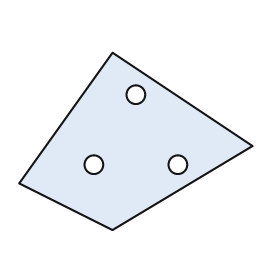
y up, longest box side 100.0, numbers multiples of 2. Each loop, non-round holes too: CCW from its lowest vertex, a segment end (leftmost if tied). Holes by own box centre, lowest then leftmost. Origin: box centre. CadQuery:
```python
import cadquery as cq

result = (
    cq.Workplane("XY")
    .moveTo(-10.0, -38.0)
    .lineTo(50.0, -2.0)
    .lineTo(-10.0, 38.0)
    .lineTo(-50.0, -18.0)
    .close()
    .moveTo(-18.0, -10.0)
    .circle(4.0)
    .moveTo(18.0, -10.0)
    .circle(4.0)
    .moveTo(0.0, 20.0)
    .circle(4.0)
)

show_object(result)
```